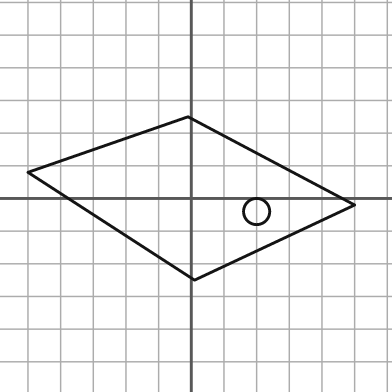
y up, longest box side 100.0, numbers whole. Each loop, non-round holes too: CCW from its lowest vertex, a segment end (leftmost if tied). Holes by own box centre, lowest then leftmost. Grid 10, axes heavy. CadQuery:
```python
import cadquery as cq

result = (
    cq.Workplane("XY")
    .moveTo(1.0, -25.0)
    .lineTo(50.0, -2.0)
    .lineTo(-1.0, 25.0)
    .lineTo(-50.0, 8.0)
    .close()
    .moveTo(20.0, -4.0)
    .circle(4.0)
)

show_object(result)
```